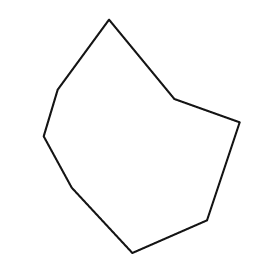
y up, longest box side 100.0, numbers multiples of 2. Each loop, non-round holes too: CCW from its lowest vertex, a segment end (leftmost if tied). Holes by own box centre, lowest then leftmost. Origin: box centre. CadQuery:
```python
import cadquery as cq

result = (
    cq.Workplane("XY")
    .moveTo(-4.0, -50.0)
    .lineTo(28.0, -36.0)
    .lineTo(42.0, 6.0)
    .lineTo(14.0, 16.0)
    .lineTo(-14.0, 50.0)
    .lineTo(-36.0, 20.0)
    .lineTo(-42.0, 0.0)
    .lineTo(-30.0, -22.0)
    .close()
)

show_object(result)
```